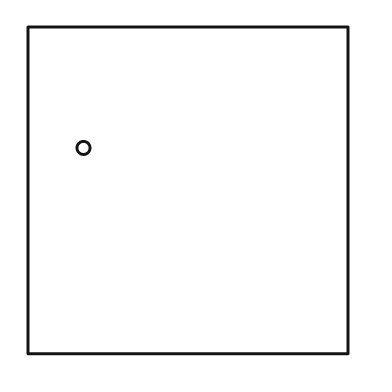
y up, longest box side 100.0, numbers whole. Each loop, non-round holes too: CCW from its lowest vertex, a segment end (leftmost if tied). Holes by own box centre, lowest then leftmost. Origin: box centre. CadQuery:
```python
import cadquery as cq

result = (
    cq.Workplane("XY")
    .moveTo(-49.0, -50.0)
    .lineTo(49.0, -50.0)
    .lineTo(49.0, 50.0)
    .lineTo(-49.0, 50.0)
    .close()
    .moveTo(-32.0, 13.0)
    .circle(2.0)
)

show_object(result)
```